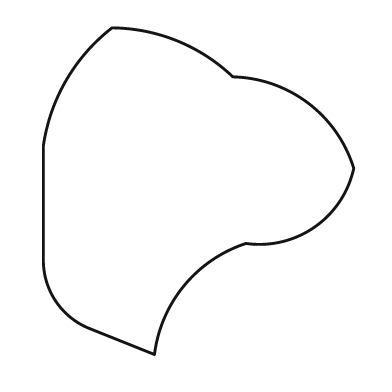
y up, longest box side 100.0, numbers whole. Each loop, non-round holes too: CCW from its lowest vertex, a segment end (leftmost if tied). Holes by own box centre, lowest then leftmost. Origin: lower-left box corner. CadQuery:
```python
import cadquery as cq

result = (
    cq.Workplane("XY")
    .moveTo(34.0, 0.0)
    .threePointArc((43.0, 21.0), (62.0, 34.0))
    .threePointArc((83.0, 39.0), (95.0, 57.0))
    .threePointArc((81.0, 77.0), (58.0, 85.0))
    .threePointArc((41.0, 96.0), (21.0, 100.0))
    .threePointArc((7.0, 84.0), (0.0, 64.0))
    .lineTo(0.0, 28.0)
    .threePointArc((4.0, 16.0), (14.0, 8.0))
    .close()
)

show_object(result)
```